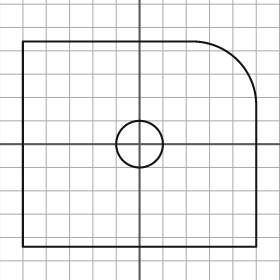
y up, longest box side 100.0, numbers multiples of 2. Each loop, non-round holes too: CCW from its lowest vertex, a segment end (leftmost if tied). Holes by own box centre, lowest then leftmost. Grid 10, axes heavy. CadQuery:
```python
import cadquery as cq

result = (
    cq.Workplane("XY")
    .moveTo(-50.0, -44.0)
    .lineTo(50.0, -44.0)
    .lineTo(50.0, 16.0)
    .threePointArc((42.0, 36.0), (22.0, 44.0))
    .lineTo(-50.0, 44.0)
    .close()
    .moveTo(0.0, 0.0)
    .circle(10.0)
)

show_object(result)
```